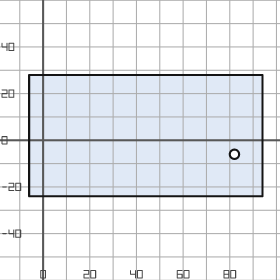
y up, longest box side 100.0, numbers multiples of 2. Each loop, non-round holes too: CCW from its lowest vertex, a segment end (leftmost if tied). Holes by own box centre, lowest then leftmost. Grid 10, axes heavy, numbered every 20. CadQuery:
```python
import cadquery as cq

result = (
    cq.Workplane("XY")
    .moveTo(-6.0, -24.0)
    .lineTo(94.0, -24.0)
    .lineTo(94.0, 28.0)
    .lineTo(-6.0, 28.0)
    .close()
    .moveTo(82.0, -6.0)
    .circle(2.0)
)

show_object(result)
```